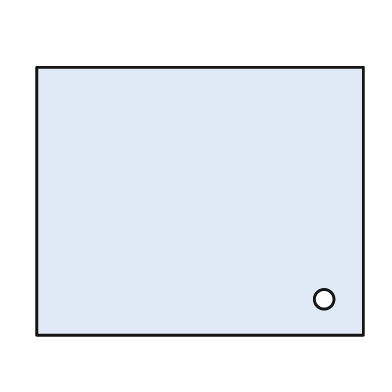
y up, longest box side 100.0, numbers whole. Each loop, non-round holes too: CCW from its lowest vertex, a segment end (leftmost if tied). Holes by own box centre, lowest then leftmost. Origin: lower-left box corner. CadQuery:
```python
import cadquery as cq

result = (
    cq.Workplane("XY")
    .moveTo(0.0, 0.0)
    .lineTo(100.0, 0.0)
    .lineTo(100.0, 82.0)
    .lineTo(0.0, 82.0)
    .close()
    .moveTo(88.0, 11.0)
    .circle(3.0)
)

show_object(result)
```